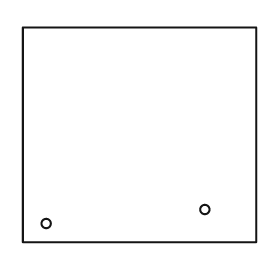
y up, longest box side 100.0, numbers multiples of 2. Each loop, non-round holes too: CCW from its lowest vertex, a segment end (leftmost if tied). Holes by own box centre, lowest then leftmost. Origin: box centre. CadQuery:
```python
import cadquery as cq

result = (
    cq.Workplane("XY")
    .moveTo(-50.0, -46.0)
    .lineTo(50.0, -46.0)
    .lineTo(50.0, 46.0)
    .lineTo(-50.0, 46.0)
    .close()
    .moveTo(-40.0, -38.0)
    .circle(2.0)
    .moveTo(28.0, -32.0)
    .circle(2.0)
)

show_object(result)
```